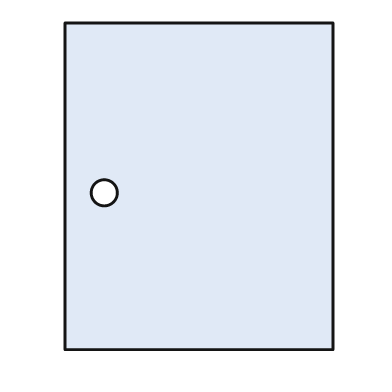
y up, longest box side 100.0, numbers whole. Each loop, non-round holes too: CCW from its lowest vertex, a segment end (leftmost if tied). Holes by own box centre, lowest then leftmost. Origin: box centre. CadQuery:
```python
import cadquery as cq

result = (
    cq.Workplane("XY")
    .moveTo(-41.0, -50.0)
    .lineTo(41.0, -50.0)
    .lineTo(41.0, 50.0)
    .lineTo(-41.0, 50.0)
    .close()
    .moveTo(-29.0, -2.0)
    .circle(4.0)
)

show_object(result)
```